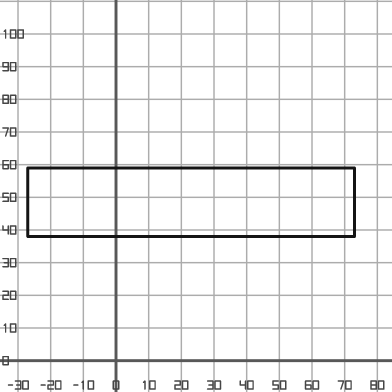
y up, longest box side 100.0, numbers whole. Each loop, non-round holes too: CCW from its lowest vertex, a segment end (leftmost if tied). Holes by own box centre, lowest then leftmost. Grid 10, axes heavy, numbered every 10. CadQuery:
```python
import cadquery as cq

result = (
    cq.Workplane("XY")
    .moveTo(-27.0, 38.0)
    .lineTo(73.0, 38.0)
    .lineTo(73.0, 59.0)
    .lineTo(-27.0, 59.0)
    .close()
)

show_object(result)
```